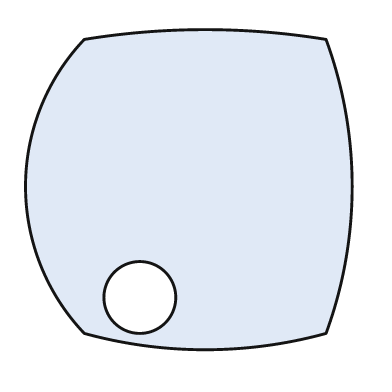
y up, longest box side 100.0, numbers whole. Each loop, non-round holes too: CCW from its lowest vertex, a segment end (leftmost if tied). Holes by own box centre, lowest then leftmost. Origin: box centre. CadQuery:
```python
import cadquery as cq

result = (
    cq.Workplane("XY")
    .moveTo(-32.0, -44.0)
    .threePointArc((5.0, -49.0), (42.0, -44.0))
    .threePointArc((50.0, 1.0), (42.0, 46.0))
    .threePointArc((5.0, 49.0), (-32.0, 46.0))
    .threePointArc((-50.0, 1.0), (-32.0, -44.0))
    .close()
    .moveTo(-15.0, -33.0)
    .circle(11.0)
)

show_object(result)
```